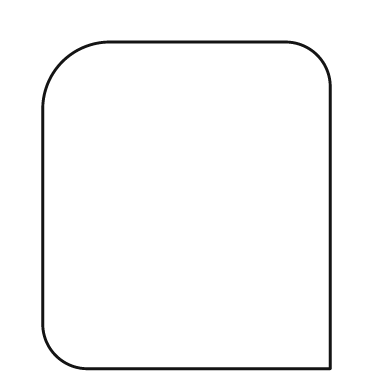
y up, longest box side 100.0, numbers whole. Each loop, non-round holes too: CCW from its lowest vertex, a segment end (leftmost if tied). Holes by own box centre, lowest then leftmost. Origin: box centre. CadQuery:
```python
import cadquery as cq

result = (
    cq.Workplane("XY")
    .moveTo(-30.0, -50.0)
    .lineTo(44.0, -50.0)
    .lineTo(44.0, 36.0)
    .threePointArc((40.0, 46.0), (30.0, 50.0))
    .lineTo(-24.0, 50.0)
    .threePointArc((-38.0, 44.0), (-44.0, 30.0))
    .lineTo(-44.0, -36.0)
    .threePointArc((-40.0, -46.0), (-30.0, -50.0))
    .close()
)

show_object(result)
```